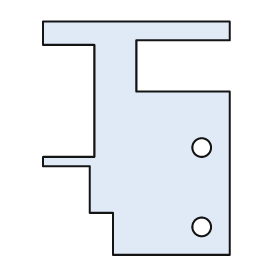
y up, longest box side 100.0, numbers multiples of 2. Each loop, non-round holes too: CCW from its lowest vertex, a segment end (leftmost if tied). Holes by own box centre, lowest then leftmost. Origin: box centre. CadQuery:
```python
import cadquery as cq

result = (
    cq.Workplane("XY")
    .moveTo(-10.0, -50.0)
    .lineTo(40.0, -50.0)
    .lineTo(40.0, 20.0)
    .lineTo(0.0, 20.0)
    .lineTo(0.0, 42.0)
    .lineTo(40.0, 42.0)
    .lineTo(40.0, 50.0)
    .lineTo(-40.0, 50.0)
    .lineTo(-40.0, 40.0)
    .lineTo(-18.0, 40.0)
    .lineTo(-18.0, -8.0)
    .lineTo(-40.0, -8.0)
    .lineTo(-40.0, -12.0)
    .lineTo(-20.0, -12.0)
    .lineTo(-20.0, -32.0)
    .lineTo(-10.0, -32.0)
    .close()
    .moveTo(28.0, -38.0)
    .circle(4.0)
    .moveTo(28.0, -4.0)
    .circle(4.0)
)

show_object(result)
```